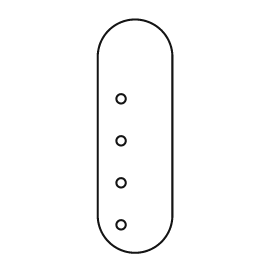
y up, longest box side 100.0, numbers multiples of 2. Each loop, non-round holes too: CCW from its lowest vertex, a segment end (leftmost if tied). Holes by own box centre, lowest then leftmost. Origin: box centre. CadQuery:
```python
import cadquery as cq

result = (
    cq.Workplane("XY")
    .moveTo(-16.0, -34.0)
    .threePointArc((0.0, -50.0), (16.0, -34.0))
    .lineTo(16.0, 34.0)
    .threePointArc((0.0, 50.0), (-16.0, 34.0))
    .close()
    .moveTo(-6.0, -38.0)
    .circle(2.0)
    .moveTo(-6.0, -20.0)
    .circle(2.0)
    .moveTo(-6.0, -2.0)
    .circle(2.0)
    .moveTo(-6.0, 16.0)
    .circle(2.0)
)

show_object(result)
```